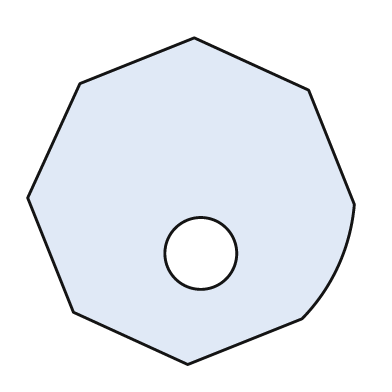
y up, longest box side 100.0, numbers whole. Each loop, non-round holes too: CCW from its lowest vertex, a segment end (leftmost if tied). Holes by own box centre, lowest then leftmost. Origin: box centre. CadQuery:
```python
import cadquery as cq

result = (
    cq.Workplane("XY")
    .moveTo(-1.0, -50.0)
    .lineTo(34.0, -36.0)
    .threePointArc((45.0, -20.0), (50.0, -1.0))
    .lineTo(36.0, 34.0)
    .lineTo(1.0, 50.0)
    .lineTo(-34.0, 36.0)
    .lineTo(-50.0, 1.0)
    .lineTo(-36.0, -34.0)
    .close()
    .moveTo(3.0, -16.0)
    .circle(11.0)
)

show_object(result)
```